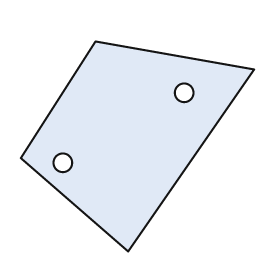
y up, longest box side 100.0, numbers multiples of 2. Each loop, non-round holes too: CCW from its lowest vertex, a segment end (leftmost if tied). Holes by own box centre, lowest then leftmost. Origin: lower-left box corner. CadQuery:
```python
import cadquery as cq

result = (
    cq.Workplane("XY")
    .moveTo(46.0, 0.0)
    .lineTo(100.0, 78.0)
    .lineTo(32.0, 90.0)
    .lineTo(0.0, 40.0)
    .close()
    .moveTo(18.0, 38.0)
    .circle(4.0)
    .moveTo(70.0, 68.0)
    .circle(4.0)
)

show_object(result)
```